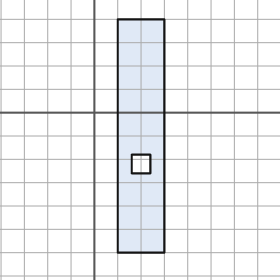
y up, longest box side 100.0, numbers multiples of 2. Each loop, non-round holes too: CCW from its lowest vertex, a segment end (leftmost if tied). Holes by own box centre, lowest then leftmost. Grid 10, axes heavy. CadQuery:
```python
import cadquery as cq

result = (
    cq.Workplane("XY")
    .moveTo(10.0, -60.0)
    .lineTo(30.0, -60.0)
    .lineTo(30.0, 40.0)
    .lineTo(10.0, 40.0)
    .close()
    .moveTo(16.0, -26.0)
    .lineTo(24.0, -26.0)
    .lineTo(24.0, -18.0)
    .lineTo(16.0, -18.0)
    .close()
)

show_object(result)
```